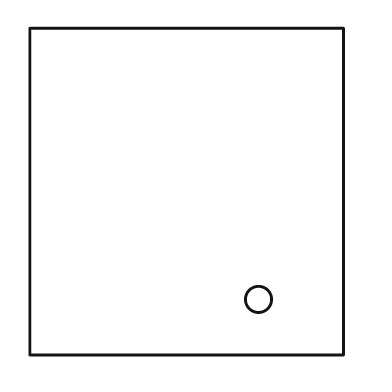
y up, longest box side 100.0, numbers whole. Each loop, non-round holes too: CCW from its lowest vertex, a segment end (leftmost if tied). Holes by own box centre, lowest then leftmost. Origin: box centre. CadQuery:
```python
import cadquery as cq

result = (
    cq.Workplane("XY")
    .moveTo(-48.0, -50.0)
    .lineTo(48.0, -50.0)
    .lineTo(48.0, 50.0)
    .lineTo(-48.0, 50.0)
    .close()
    .moveTo(22.0, -33.0)
    .circle(4.0)
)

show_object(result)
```